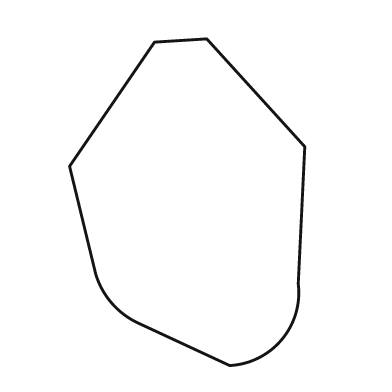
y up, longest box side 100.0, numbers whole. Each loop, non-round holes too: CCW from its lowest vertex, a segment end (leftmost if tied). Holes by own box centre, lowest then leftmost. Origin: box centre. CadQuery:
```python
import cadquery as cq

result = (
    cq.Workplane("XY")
    .moveTo(13.0, -50.0)
    .threePointArc((29.0, -42.0), (34.0, -25.0))
    .lineTo(36.0, 17.0)
    .lineTo(6.0, 50.0)
    .lineTo(-10.0, 49.0)
    .lineTo(-36.0, 11.0)
    .lineTo(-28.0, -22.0)
    .threePointArc((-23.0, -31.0), (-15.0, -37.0))
    .close()
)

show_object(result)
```